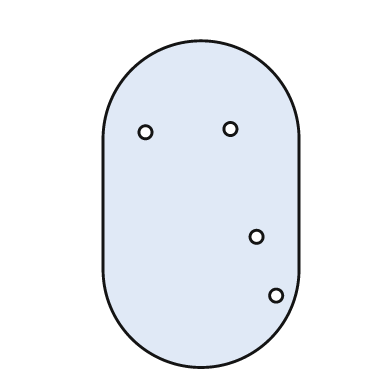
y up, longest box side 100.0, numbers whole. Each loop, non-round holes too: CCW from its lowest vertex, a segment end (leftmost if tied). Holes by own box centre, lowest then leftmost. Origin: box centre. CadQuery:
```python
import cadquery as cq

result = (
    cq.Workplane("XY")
    .moveTo(-30.0, -20.0)
    .threePointArc((0.0, -50.0), (30.0, -20.0))
    .lineTo(30.0, 20.0)
    .threePointArc((0.0, 50.0), (-30.0, 20.0))
    .close()
    .moveTo(23.0, -28.0)
    .circle(2.0)
    .moveTo(17.0, -10.0)
    .circle(2.0)
    .moveTo(-17.0, 22.0)
    .circle(2.0)
    .moveTo(9.0, 23.0)
    .circle(2.0)
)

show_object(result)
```